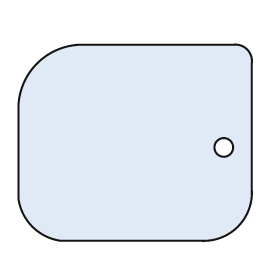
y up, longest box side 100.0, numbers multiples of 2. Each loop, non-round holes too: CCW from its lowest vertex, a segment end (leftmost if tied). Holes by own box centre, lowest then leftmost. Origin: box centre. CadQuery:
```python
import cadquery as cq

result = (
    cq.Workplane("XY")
    .moveTo(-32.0, -42.0)
    .lineTo(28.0, -42.0)
    .threePointArc((44.0, -36.0), (50.0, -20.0))
    .lineTo(50.0, 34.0)
    .threePointArc((48.0, 40.0), (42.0, 42.0))
    .lineTo(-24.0, 42.0)
    .threePointArc((-42.0, 34.0), (-50.0, 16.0))
    .lineTo(-50.0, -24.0)
    .threePointArc((-44.0, -36.0), (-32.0, -42.0))
    .close()
    .moveTo(38.0, -2.0)
    .circle(4.0)
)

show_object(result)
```